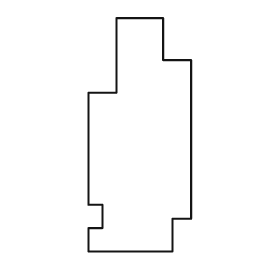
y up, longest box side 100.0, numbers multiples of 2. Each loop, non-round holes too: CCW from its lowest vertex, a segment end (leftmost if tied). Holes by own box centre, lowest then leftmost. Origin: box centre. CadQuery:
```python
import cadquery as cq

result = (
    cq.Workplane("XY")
    .moveTo(-22.0, -50.0)
    .lineTo(14.0, -50.0)
    .lineTo(14.0, -36.0)
    .lineTo(22.0, -36.0)
    .lineTo(22.0, 32.0)
    .lineTo(10.0, 32.0)
    .lineTo(10.0, 50.0)
    .lineTo(-10.0, 50.0)
    .lineTo(-10.0, 18.0)
    .lineTo(-22.0, 18.0)
    .lineTo(-22.0, -30.0)
    .lineTo(-16.0, -30.0)
    .lineTo(-16.0, -40.0)
    .lineTo(-22.0, -40.0)
    .close()
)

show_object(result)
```